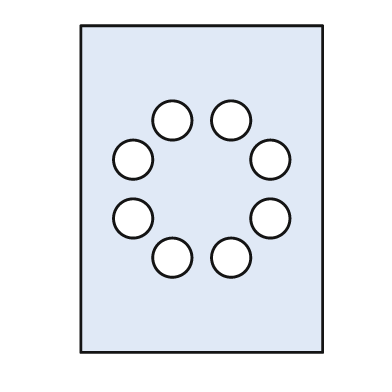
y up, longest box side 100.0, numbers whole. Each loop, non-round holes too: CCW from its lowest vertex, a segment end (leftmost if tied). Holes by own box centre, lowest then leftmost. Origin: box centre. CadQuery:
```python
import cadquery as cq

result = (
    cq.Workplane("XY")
    .moveTo(-37.0, -50.0)
    .lineTo(37.0, -50.0)
    .lineTo(37.0, 50.0)
    .lineTo(-37.0, 50.0)
    .close()
    .moveTo(-9.0, -21.0)
    .circle(6.0)
    .moveTo(9.0, -21.0)
    .circle(6.0)
    .moveTo(-21.0, -9.0)
    .circle(6.0)
    .moveTo(21.0, -9.0)
    .circle(6.0)
    .moveTo(-21.0, 9.0)
    .circle(6.0)
    .moveTo(21.0, 9.0)
    .circle(6.0)
    .moveTo(-9.0, 21.0)
    .circle(6.0)
    .moveTo(9.0, 21.0)
    .circle(6.0)
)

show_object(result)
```